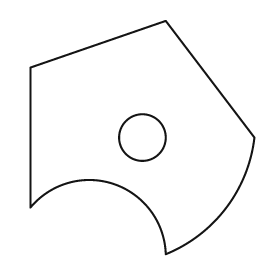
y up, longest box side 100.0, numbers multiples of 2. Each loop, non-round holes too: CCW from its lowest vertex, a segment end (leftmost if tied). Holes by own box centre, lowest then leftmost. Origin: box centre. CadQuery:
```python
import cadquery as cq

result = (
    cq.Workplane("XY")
    .moveTo(10.0, -50.0)
    .threePointArc((36.0, -30.0), (48.0, 0.0))
    .lineTo(10.0, 50.0)
    .lineTo(-48.0, 30.0)
    .lineTo(-48.0, -30.0)
    .threePointArc((-12.0, -20.0), (10.0, -50.0))
    .close()
    .moveTo(0.0, 0.0)
    .circle(10.0)
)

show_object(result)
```